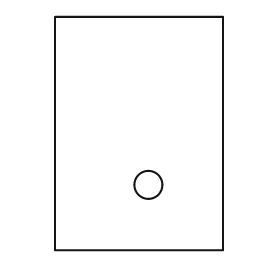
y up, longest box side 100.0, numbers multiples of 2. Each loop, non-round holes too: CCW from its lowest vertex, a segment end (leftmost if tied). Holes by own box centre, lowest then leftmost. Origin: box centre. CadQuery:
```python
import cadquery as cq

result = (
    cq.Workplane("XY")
    .moveTo(-36.0, -50.0)
    .lineTo(36.0, -50.0)
    .lineTo(36.0, 50.0)
    .lineTo(-36.0, 50.0)
    .close()
    .moveTo(4.0, -22.0)
    .circle(6.0)
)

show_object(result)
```